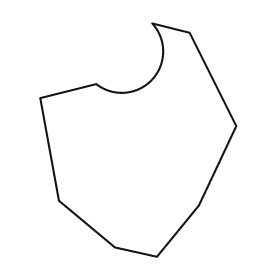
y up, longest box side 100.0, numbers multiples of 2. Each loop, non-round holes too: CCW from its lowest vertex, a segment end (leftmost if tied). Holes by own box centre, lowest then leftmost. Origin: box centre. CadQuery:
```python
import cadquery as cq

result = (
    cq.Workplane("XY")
    .moveTo(8.0, -50.0)
    .lineTo(26.0, -28.0)
    .lineTo(42.0, 6.0)
    .lineTo(22.0, 46.0)
    .lineTo(6.0, 50.0)
    .threePointArc((6.0, 26.0), (-18.0, 24.0))
    .lineTo(-42.0, 18.0)
    .lineTo(-34.0, -26.0)
    .lineTo(-10.0, -46.0)
    .close()
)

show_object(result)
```